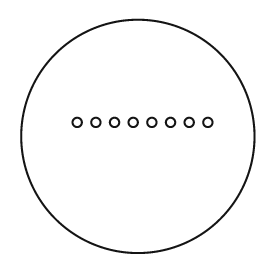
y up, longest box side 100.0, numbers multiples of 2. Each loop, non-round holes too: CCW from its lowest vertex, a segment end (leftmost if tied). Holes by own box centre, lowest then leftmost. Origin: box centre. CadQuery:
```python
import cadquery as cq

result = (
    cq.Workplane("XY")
    .moveTo(0.0, 0.0)
    .circle(50.0)
    .moveTo(-26.0, 6.0)
    .circle(2.0)
    .moveTo(-18.0, 6.0)
    .circle(2.0)
    .moveTo(-10.0, 6.0)
    .circle(2.0)
    .moveTo(-2.0, 6.0)
    .circle(2.0)
    .moveTo(6.0, 6.0)
    .circle(2.0)
    .moveTo(14.0, 6.0)
    .circle(2.0)
    .moveTo(22.0, 6.0)
    .circle(2.0)
    .moveTo(30.0, 6.0)
    .circle(2.0)
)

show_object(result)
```